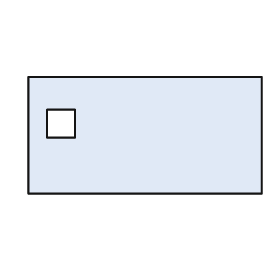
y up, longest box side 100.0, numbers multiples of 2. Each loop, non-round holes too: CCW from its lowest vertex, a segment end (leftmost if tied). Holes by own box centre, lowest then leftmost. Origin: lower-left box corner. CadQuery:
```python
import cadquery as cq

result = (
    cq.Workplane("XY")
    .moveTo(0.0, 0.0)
    .lineTo(100.0, 0.0)
    .lineTo(100.0, 50.0)
    .lineTo(0.0, 50.0)
    .close()
    .moveTo(8.0, 24.0)
    .lineTo(20.0, 24.0)
    .lineTo(20.0, 36.0)
    .lineTo(8.0, 36.0)
    .close()
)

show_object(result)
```